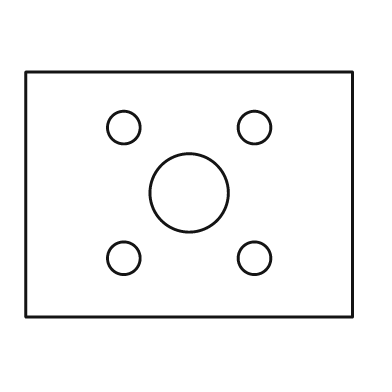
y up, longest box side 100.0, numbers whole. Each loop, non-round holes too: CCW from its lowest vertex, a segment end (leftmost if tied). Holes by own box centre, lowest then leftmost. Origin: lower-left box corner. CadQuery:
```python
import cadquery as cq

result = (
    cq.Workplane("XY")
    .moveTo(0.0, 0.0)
    .lineTo(100.0, 0.0)
    .lineTo(100.0, 75.0)
    .lineTo(0.0, 75.0)
    .close()
    .moveTo(30.0, 18.0)
    .circle(5.0)
    .moveTo(70.0, 18.0)
    .circle(5.0)
    .moveTo(50.0, 38.0)
    .circle(12.0)
    .moveTo(30.0, 58.0)
    .circle(5.0)
    .moveTo(70.0, 58.0)
    .circle(5.0)
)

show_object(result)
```